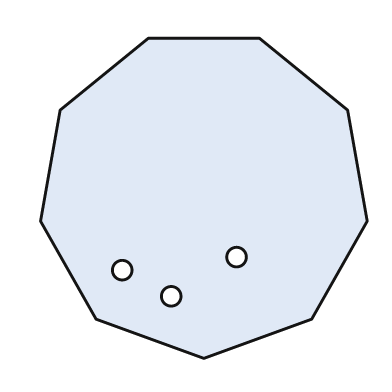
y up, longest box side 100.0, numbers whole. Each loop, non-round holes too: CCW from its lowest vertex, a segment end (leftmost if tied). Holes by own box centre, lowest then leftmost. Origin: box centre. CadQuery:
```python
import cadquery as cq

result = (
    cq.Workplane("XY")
    .moveTo(0.0, -49.0)
    .lineTo(33.0, -37.0)
    .lineTo(50.0, -7.0)
    .lineTo(44.0, 27.0)
    .lineTo(17.0, 49.0)
    .lineTo(-17.0, 49.0)
    .lineTo(-44.0, 27.0)
    .lineTo(-50.0, -7.0)
    .lineTo(-33.0, -37.0)
    .close()
    .moveTo(-10.0, -30.0)
    .circle(3.0)
    .moveTo(-25.0, -22.0)
    .circle(3.0)
    .moveTo(10.0, -18.0)
    .circle(3.0)
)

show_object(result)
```